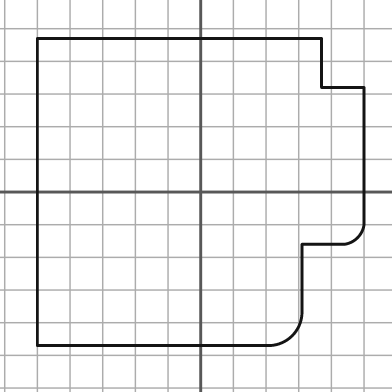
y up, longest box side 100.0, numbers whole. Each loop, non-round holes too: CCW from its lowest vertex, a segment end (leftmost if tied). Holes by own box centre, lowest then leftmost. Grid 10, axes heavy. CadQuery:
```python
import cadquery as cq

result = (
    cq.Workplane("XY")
    .moveTo(-50.0, -47.0)
    .lineTo(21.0, -47.0)
    .threePointArc((28.0, -44.0), (31.0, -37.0))
    .lineTo(31.0, -16.0)
    .lineTo(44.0, -16.0)
    .threePointArc((48.0, -14.0), (50.0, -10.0))
    .lineTo(50.0, 32.0)
    .lineTo(37.0, 32.0)
    .lineTo(37.0, 47.0)
    .lineTo(-50.0, 47.0)
    .close()
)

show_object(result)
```